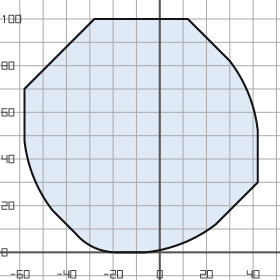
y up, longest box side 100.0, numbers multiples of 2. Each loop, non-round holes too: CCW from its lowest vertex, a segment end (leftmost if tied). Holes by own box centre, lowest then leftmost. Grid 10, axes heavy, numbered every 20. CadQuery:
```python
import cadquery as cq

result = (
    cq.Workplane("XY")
    .moveTo(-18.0, 0.0)
    .lineTo(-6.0, 0.0)
    .threePointArc((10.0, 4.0), (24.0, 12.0))
    .lineTo(42.0, 30.0)
    .lineTo(42.0, 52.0)
    .threePointArc((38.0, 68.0), (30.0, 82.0))
    .lineTo(12.0, 100.0)
    .lineTo(-28.0, 100.0)
    .lineTo(-58.0, 70.0)
    .lineTo(-58.0, 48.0)
    .threePointArc((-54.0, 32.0), (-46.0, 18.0))
    .lineTo(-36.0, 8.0)
    .threePointArc((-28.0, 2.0), (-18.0, 0.0))
    .close()
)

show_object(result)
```